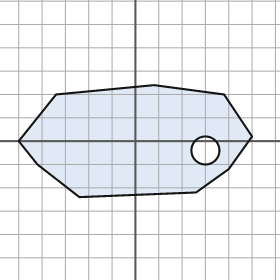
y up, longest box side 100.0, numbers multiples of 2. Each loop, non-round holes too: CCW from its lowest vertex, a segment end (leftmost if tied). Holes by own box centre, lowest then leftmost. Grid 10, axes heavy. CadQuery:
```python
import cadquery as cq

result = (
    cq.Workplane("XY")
    .moveTo(-24.0, -24.0)
    .lineTo(26.0, -22.0)
    .lineTo(40.0, -12.0)
    .lineTo(50.0, 2.0)
    .lineTo(38.0, 20.0)
    .lineTo(8.0, 24.0)
    .lineTo(-34.0, 20.0)
    .lineTo(-50.0, 0.0)
    .lineTo(-42.0, -10.0)
    .close()
    .moveTo(30.0, -4.0)
    .circle(6.0)
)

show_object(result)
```